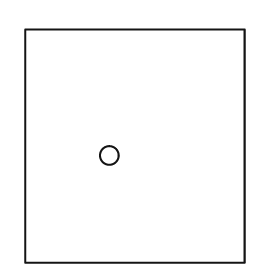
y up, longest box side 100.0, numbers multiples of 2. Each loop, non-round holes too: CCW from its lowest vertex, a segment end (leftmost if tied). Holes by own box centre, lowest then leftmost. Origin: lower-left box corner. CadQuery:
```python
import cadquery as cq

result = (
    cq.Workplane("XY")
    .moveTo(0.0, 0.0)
    .lineTo(94.0, 0.0)
    .lineTo(94.0, 100.0)
    .lineTo(0.0, 100.0)
    .close()
    .moveTo(36.0, 46.0)
    .circle(4.0)
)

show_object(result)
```